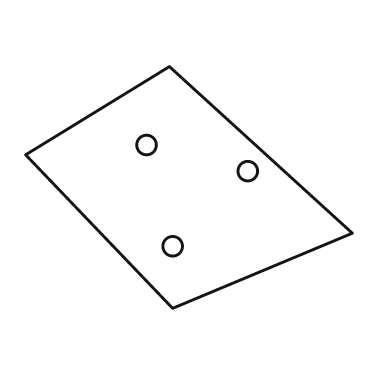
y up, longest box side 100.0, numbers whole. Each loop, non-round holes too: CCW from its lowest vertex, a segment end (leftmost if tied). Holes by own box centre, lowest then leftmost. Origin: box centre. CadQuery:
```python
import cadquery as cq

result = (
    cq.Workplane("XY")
    .moveTo(-5.0, -37.0)
    .lineTo(50.0, -14.0)
    .lineTo(-6.0, 37.0)
    .lineTo(-50.0, 10.0)
    .close()
    .moveTo(-5.0, -18.0)
    .circle(3.0)
    .moveTo(18.0, 5.0)
    .circle(3.0)
    .moveTo(-13.0, 13.0)
    .circle(3.0)
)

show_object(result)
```